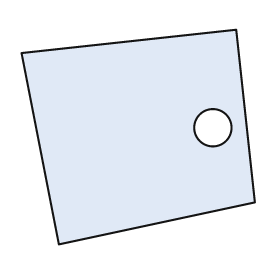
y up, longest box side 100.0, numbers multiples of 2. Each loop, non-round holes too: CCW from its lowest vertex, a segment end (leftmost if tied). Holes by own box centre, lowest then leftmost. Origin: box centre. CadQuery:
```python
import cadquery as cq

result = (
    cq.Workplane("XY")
    .moveTo(-34.0, -46.0)
    .lineTo(50.0, -28.0)
    .lineTo(42.0, 46.0)
    .lineTo(-50.0, 36.0)
    .close()
    .moveTo(32.0, 4.0)
    .circle(8.0)
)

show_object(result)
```